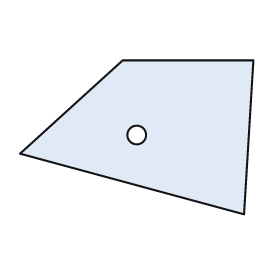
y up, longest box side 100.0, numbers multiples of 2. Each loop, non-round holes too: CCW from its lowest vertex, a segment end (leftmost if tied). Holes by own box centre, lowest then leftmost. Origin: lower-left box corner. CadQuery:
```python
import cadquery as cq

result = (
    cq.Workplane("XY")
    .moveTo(96.0, 0.0)
    .lineTo(100.0, 66.0)
    .lineTo(44.0, 66.0)
    .lineTo(0.0, 26.0)
    .close()
    .moveTo(50.0, 34.0)
    .circle(4.0)
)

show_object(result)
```